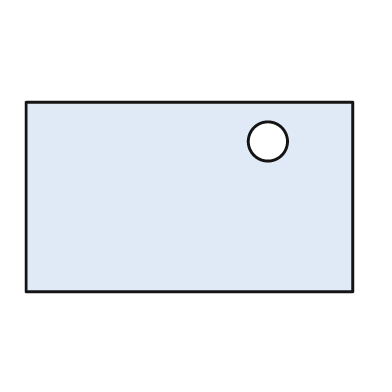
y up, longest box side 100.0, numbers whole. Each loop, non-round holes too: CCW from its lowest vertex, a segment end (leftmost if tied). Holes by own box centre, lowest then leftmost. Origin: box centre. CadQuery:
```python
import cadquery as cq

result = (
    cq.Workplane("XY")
    .moveTo(-50.0, -29.0)
    .lineTo(50.0, -29.0)
    .lineTo(50.0, 29.0)
    .lineTo(-50.0, 29.0)
    .close()
    .moveTo(24.0, 17.0)
    .circle(6.0)
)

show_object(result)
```